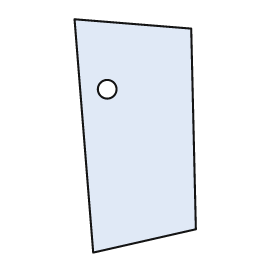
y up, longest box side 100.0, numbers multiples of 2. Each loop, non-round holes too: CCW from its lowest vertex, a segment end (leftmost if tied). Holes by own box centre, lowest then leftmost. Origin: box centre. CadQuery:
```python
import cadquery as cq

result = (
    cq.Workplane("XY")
    .moveTo(-18.0, -50.0)
    .lineTo(26.0, -40.0)
    .lineTo(24.0, 46.0)
    .lineTo(-26.0, 50.0)
    .close()
    .moveTo(-12.0, 20.0)
    .circle(4.0)
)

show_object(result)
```